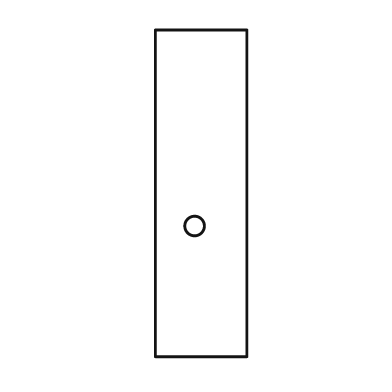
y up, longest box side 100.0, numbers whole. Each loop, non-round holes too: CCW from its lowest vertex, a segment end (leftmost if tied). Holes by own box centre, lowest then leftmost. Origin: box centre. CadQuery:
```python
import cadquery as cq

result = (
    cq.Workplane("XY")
    .moveTo(-14.0, -50.0)
    .lineTo(14.0, -50.0)
    .lineTo(14.0, 50.0)
    .lineTo(-14.0, 50.0)
    .close()
    .moveTo(-2.0, -10.0)
    .circle(3.0)
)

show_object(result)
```